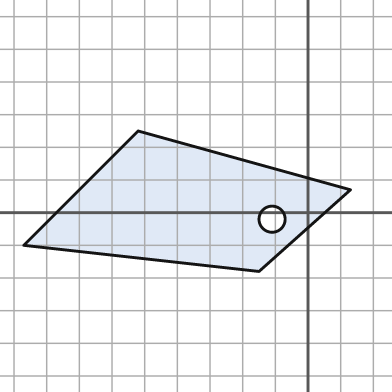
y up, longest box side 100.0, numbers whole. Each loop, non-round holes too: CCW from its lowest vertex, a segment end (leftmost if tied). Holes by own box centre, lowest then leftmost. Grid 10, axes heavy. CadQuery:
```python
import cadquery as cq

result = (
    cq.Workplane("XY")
    .moveTo(-15.0, -18.0)
    .lineTo(13.0, 7.0)
    .lineTo(-52.0, 25.0)
    .lineTo(-87.0, -10.0)
    .close()
    .moveTo(-11.0, -2.0)
    .circle(4.0)
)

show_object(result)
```